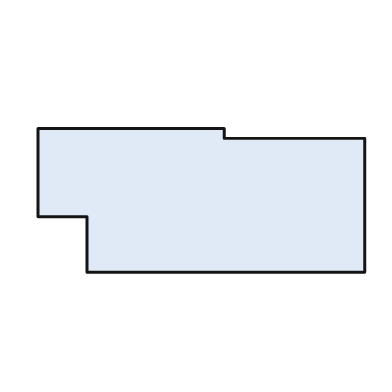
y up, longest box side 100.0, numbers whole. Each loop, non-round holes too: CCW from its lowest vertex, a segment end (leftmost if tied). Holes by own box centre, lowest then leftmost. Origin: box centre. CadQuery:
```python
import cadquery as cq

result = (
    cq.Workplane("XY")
    .moveTo(-35.0, -22.0)
    .lineTo(50.0, -22.0)
    .lineTo(50.0, 19.0)
    .lineTo(7.0, 19.0)
    .lineTo(7.0, 22.0)
    .lineTo(-50.0, 22.0)
    .lineTo(-50.0, -5.0)
    .lineTo(-35.0, -5.0)
    .close()
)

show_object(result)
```